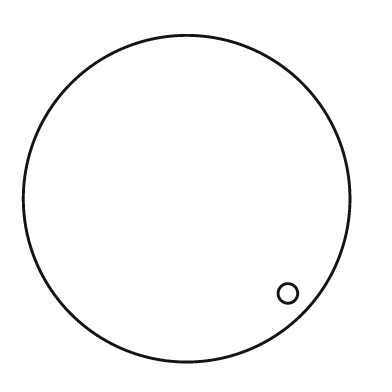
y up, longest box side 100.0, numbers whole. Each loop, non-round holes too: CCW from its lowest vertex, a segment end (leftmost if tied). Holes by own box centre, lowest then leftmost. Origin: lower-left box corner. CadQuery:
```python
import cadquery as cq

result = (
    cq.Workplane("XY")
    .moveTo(50.0, 50.0)
    .circle(50.0)
    .moveTo(81.0, 21.0)
    .circle(3.0)
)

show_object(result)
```